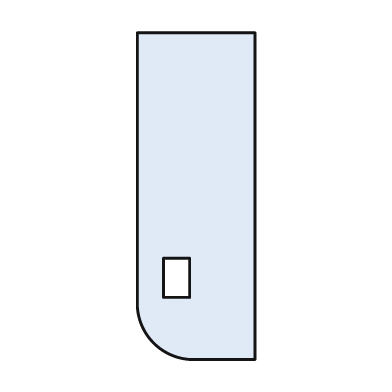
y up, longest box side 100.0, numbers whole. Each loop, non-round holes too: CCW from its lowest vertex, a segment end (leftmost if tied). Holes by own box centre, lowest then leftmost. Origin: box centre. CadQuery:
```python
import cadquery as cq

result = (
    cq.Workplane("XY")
    .moveTo(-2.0, -50.0)
    .lineTo(18.0, -50.0)
    .lineTo(18.0, 50.0)
    .lineTo(-18.0, 50.0)
    .lineTo(-18.0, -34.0)
    .threePointArc((-13.0, -45.0), (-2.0, -50.0))
    .close()
    .moveTo(-10.0, -31.0)
    .lineTo(-2.0, -31.0)
    .lineTo(-2.0, -19.0)
    .lineTo(-10.0, -19.0)
    .close()
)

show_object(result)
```